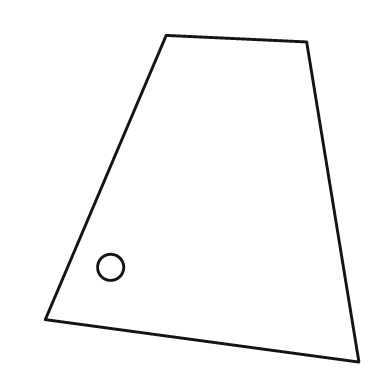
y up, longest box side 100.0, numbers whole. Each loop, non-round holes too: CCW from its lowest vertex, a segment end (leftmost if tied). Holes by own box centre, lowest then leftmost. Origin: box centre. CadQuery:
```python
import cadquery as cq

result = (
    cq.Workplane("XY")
    .moveTo(48.0, -50.0)
    .lineTo(32.0, 48.0)
    .lineTo(-11.0, 50.0)
    .lineTo(-48.0, -37.0)
    .close()
    .moveTo(-28.0, -21.0)
    .circle(4.0)
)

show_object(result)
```